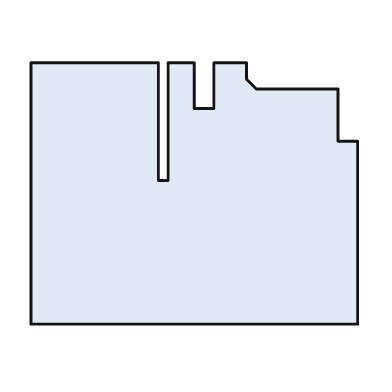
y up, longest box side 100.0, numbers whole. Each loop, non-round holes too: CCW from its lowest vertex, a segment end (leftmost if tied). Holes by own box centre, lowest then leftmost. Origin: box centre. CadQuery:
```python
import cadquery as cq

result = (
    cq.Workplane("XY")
    .moveTo(-50.0, -40.0)
    .lineTo(50.0, -40.0)
    .lineTo(50.0, 16.0)
    .lineTo(44.0, 16.0)
    .lineTo(44.0, 32.0)
    .lineTo(19.0, 32.0)
    .lineTo(16.0, 35.0)
    .lineTo(16.0, 40.0)
    .lineTo(6.0, 40.0)
    .lineTo(6.0, 26.0)
    .lineTo(0.0, 26.0)
    .lineTo(0.0, 40.0)
    .lineTo(-8.0, 40.0)
    .lineTo(-8.0, 4.0)
    .lineTo(-11.0, 4.0)
    .lineTo(-11.0, 40.0)
    .lineTo(-50.0, 40.0)
    .close()
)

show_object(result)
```